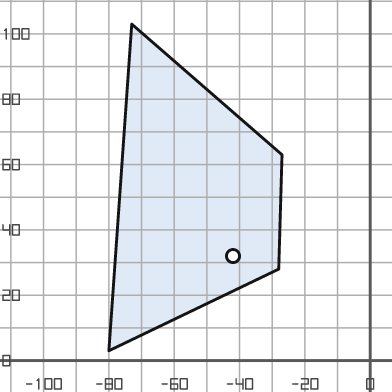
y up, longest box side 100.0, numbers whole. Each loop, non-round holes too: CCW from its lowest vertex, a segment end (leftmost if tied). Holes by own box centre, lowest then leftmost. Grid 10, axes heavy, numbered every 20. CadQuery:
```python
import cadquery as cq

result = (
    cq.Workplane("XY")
    .moveTo(-80.0, 3.0)
    .lineTo(-28.0, 28.0)
    .lineTo(-27.0, 63.0)
    .lineTo(-73.0, 103.0)
    .close()
    .moveTo(-42.0, 32.0)
    .circle(2.0)
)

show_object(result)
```